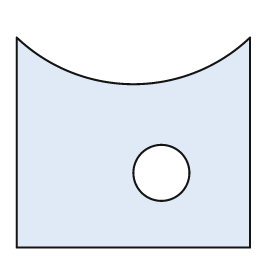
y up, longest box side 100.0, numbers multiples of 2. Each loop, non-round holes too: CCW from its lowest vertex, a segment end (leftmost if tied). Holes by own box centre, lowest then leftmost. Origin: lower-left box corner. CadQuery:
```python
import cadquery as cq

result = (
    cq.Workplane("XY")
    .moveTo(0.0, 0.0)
    .lineTo(100.0, 0.0)
    .lineTo(100.0, 90.0)
    .threePointArc((50.0, 70.0), (0.0, 90.0))
    .close()
    .moveTo(62.0, 32.0)
    .circle(12.0)
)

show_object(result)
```